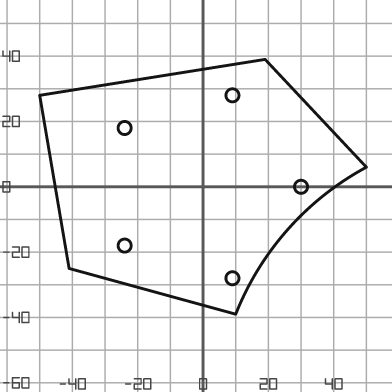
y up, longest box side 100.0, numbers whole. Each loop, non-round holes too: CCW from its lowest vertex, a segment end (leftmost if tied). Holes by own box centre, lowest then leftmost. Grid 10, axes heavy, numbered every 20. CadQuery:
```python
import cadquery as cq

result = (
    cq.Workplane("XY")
    .moveTo(10.0, -39.0)
    .threePointArc((26.0, -13.0), (50.0, 6.0))
    .lineTo(19.0, 39.0)
    .lineTo(-50.0, 28.0)
    .lineTo(-41.0, -25.0)
    .close()
    .moveTo(9.0, -28.0)
    .circle(2.0)
    .moveTo(-24.0, -18.0)
    .circle(2.0)
    .moveTo(30.0, 0.0)
    .circle(2.0)
    .moveTo(-24.0, 18.0)
    .circle(2.0)
    .moveTo(9.0, 28.0)
    .circle(2.0)
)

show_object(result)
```